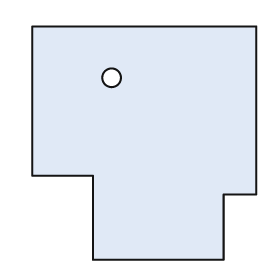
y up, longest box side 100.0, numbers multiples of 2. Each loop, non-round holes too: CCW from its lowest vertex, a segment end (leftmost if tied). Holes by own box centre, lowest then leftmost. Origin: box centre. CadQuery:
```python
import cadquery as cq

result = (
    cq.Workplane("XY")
    .moveTo(-22.0, -50.0)
    .lineTo(34.0, -50.0)
    .lineTo(34.0, -22.0)
    .lineTo(48.0, -22.0)
    .lineTo(48.0, 50.0)
    .lineTo(-48.0, 50.0)
    .lineTo(-48.0, -14.0)
    .lineTo(-22.0, -14.0)
    .close()
    .moveTo(-14.0, 28.0)
    .circle(4.0)
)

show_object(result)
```